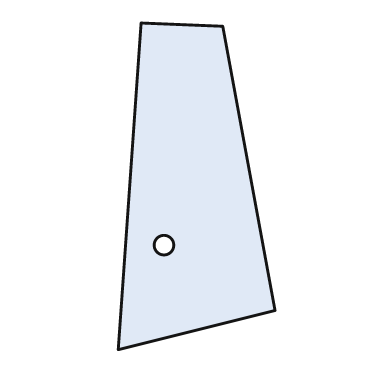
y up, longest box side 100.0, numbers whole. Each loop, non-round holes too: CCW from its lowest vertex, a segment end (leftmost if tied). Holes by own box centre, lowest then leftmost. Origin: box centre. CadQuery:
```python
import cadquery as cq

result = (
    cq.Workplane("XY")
    .moveTo(-24.0, -50.0)
    .lineTo(24.0, -38.0)
    .lineTo(8.0, 49.0)
    .lineTo(-17.0, 50.0)
    .close()
    .moveTo(-10.0, -18.0)
    .circle(3.0)
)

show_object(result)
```